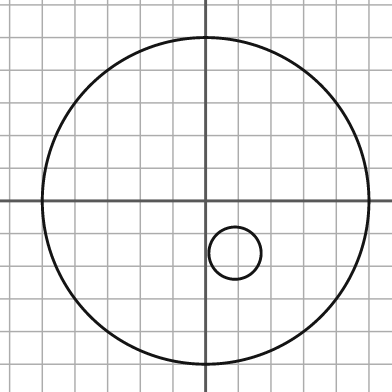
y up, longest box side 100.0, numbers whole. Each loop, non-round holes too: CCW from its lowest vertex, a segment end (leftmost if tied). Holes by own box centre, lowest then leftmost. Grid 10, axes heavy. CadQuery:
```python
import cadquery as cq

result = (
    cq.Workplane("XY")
    .moveTo(0.0, 0.0)
    .circle(50.0)
    .moveTo(9.0, -16.0)
    .circle(8.0)
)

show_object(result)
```